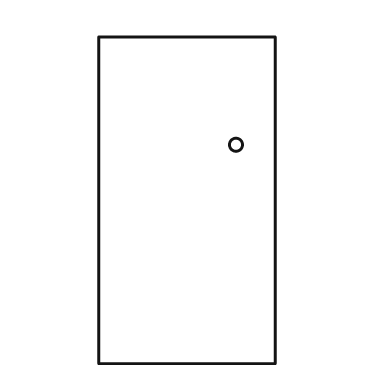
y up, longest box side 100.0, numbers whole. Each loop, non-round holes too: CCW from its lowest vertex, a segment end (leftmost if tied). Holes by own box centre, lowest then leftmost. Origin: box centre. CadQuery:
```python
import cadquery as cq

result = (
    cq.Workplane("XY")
    .moveTo(-27.0, -50.0)
    .lineTo(27.0, -50.0)
    .lineTo(27.0, 50.0)
    .lineTo(-27.0, 50.0)
    .close()
    .moveTo(15.0, 17.0)
    .circle(2.0)
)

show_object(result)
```